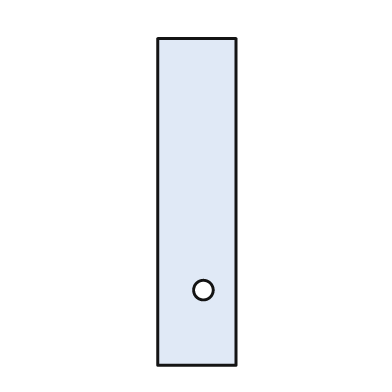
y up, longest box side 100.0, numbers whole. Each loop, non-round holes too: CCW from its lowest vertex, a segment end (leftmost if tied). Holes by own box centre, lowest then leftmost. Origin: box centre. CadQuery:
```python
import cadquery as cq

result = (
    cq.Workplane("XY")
    .moveTo(-12.0, -50.0)
    .lineTo(12.0, -50.0)
    .lineTo(12.0, 50.0)
    .lineTo(-12.0, 50.0)
    .close()
    .moveTo(2.0, -27.0)
    .circle(3.0)
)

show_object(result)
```